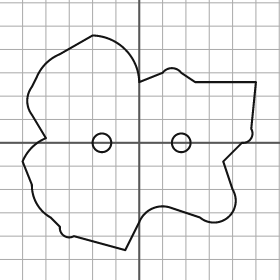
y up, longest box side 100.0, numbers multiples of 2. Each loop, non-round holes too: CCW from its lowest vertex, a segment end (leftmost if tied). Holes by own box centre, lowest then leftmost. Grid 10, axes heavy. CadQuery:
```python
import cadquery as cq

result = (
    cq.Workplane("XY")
    .moveTo(-6.0, -46.0)
    .lineTo(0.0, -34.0)
    .threePointArc((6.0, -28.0), (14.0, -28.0))
    .lineTo(26.0, -32.0)
    .threePointArc((38.0, -32.0), (40.0, -20.0))
    .lineTo(36.0, -8.0)
    .lineTo(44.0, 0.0)
    .threePointArc((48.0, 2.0), (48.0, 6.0))
    .lineTo(50.0, 26.0)
    .lineTo(24.0, 26.0)
    .lineTo(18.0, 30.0)
    .threePointArc((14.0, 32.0), (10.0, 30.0))
    .lineTo(0.0, 26.0)
    .threePointArc((-6.0, 40.0), (-20.0, 46.0))
    .lineTo(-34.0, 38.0)
    .threePointArc((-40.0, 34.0), (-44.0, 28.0))
    .lineTo(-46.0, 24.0)
    .threePointArc((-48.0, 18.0), (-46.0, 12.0))
    .lineTo(-40.0, 2.0)
    .threePointArc((-46.0, -2.0), (-50.0, -8.0))
    .lineTo(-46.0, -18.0)
    .threePointArc((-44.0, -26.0), (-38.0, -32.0))
    .lineTo(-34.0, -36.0)
    .threePointArc((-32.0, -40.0), (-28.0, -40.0))
    .close()
    .moveTo(-16.0, 0.0)
    .circle(4.0)
    .moveTo(18.0, 0.0)
    .circle(4.0)
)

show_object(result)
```